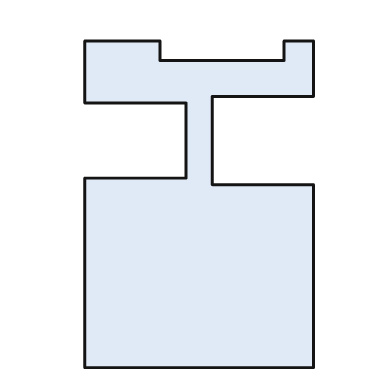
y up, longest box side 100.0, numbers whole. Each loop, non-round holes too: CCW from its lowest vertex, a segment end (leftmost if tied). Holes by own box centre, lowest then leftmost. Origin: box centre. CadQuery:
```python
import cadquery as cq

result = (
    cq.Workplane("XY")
    .moveTo(-35.0, -50.0)
    .lineTo(35.0, -50.0)
    .lineTo(35.0, 6.0)
    .lineTo(4.0, 6.0)
    .lineTo(4.0, 33.0)
    .lineTo(35.0, 33.0)
    .lineTo(35.0, 50.0)
    .lineTo(26.0, 50.0)
    .lineTo(26.0, 44.0)
    .lineTo(-12.0, 44.0)
    .lineTo(-12.0, 50.0)
    .lineTo(-35.0, 50.0)
    .lineTo(-35.0, 31.0)
    .lineTo(-4.0, 31.0)
    .lineTo(-4.0, 8.0)
    .lineTo(-35.0, 8.0)
    .close()
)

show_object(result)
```